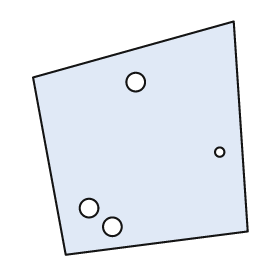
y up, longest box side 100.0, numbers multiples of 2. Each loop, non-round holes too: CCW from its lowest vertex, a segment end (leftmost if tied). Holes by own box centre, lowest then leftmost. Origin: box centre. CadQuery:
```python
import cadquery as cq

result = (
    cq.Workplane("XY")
    .moveTo(-32.0, -50.0)
    .lineTo(46.0, -40.0)
    .lineTo(40.0, 50.0)
    .lineTo(-46.0, 26.0)
    .close()
    .moveTo(-12.0, -38.0)
    .circle(4.0)
    .moveTo(-22.0, -30.0)
    .circle(4.0)
    .moveTo(34.0, -6.0)
    .circle(2.0)
    .moveTo(-2.0, 24.0)
    .circle(4.0)
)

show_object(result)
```